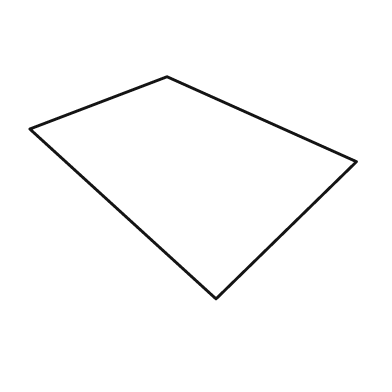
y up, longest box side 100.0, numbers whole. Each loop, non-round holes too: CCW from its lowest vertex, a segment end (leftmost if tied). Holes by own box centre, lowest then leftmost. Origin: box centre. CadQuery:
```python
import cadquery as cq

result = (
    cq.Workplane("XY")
    .moveTo(7.0, -34.0)
    .lineTo(50.0, 8.0)
    .lineTo(-8.0, 34.0)
    .lineTo(-50.0, 18.0)
    .close()
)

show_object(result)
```